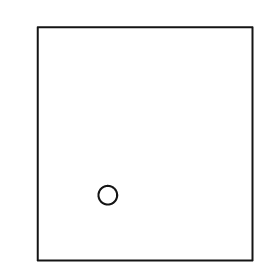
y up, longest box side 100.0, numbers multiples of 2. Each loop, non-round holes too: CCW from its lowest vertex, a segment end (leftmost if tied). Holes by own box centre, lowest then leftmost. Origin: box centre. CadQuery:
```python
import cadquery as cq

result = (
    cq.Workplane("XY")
    .moveTo(-46.0, -50.0)
    .lineTo(46.0, -50.0)
    .lineTo(46.0, 50.0)
    .lineTo(-46.0, 50.0)
    .close()
    .moveTo(-16.0, -22.0)
    .circle(4.0)
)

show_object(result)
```